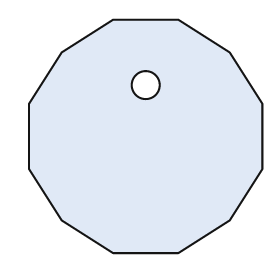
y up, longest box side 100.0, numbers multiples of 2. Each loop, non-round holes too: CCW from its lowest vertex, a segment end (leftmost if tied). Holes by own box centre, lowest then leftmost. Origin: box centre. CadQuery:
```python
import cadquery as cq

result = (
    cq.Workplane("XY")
    .moveTo(-14.0, -50.0)
    .lineTo(14.0, -50.0)
    .lineTo(36.0, -36.0)
    .lineTo(50.0, -14.0)
    .lineTo(50.0, 14.0)
    .lineTo(36.0, 36.0)
    .lineTo(14.0, 50.0)
    .lineTo(-14.0, 50.0)
    .lineTo(-36.0, 36.0)
    .lineTo(-50.0, 14.0)
    .lineTo(-50.0, -14.0)
    .lineTo(-36.0, -36.0)
    .close()
    .moveTo(0.0, 22.0)
    .circle(6.0)
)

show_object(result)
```